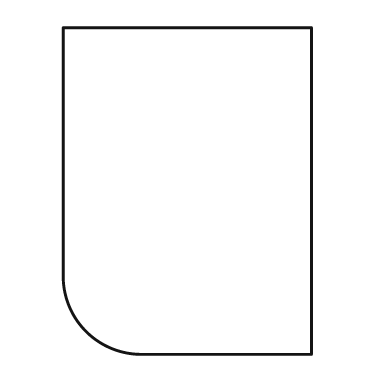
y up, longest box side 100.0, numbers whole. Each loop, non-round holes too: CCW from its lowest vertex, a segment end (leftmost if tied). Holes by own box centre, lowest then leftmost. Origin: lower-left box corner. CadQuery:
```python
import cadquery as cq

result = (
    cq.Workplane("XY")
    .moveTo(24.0, 0.0)
    .lineTo(76.0, 0.0)
    .lineTo(76.0, 100.0)
    .lineTo(0.0, 100.0)
    .lineTo(0.0, 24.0)
    .threePointArc((7.0, 7.0), (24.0, 0.0))
    .close()
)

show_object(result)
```